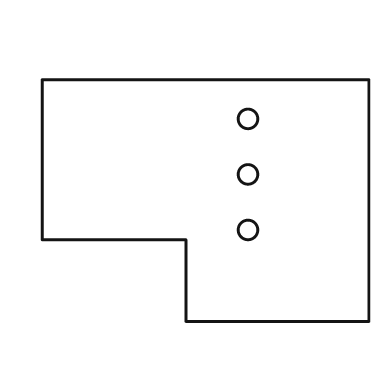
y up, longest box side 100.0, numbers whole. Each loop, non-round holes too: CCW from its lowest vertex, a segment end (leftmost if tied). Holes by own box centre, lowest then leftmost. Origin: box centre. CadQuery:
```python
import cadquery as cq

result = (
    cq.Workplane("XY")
    .moveTo(-6.0, -37.0)
    .lineTo(50.0, -37.0)
    .lineTo(50.0, 37.0)
    .lineTo(-50.0, 37.0)
    .lineTo(-50.0, -12.0)
    .lineTo(-6.0, -12.0)
    .close()
    .moveTo(13.0, -9.0)
    .circle(3.0)
    .moveTo(13.0, 8.0)
    .circle(3.0)
    .moveTo(13.0, 25.0)
    .circle(3.0)
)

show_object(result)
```